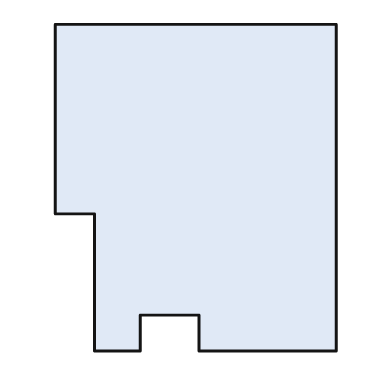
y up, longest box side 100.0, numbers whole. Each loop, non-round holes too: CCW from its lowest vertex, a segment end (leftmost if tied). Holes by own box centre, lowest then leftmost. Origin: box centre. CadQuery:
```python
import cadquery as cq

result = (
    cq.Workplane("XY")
    .moveTo(-31.0, -50.0)
    .lineTo(-17.0, -50.0)
    .lineTo(-17.0, -39.0)
    .lineTo(1.0, -39.0)
    .lineTo(1.0, -50.0)
    .lineTo(43.0, -50.0)
    .lineTo(43.0, 50.0)
    .lineTo(-43.0, 50.0)
    .lineTo(-43.0, -8.0)
    .lineTo(-31.0, -8.0)
    .close()
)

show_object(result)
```